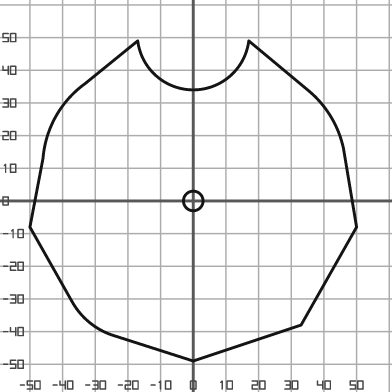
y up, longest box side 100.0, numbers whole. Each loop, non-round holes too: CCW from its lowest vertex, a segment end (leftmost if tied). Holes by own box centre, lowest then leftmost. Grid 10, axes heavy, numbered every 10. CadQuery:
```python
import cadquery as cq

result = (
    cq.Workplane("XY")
    .moveTo(0.0, -49.0)
    .lineTo(33.0, -38.0)
    .lineTo(50.0, -8.0)
    .lineTo(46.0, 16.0)
    .threePointArc((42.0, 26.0), (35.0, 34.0))
    .lineTo(17.0, 49.0)
    .threePointArc((0.0, 34.0), (-17.0, 49.0))
    .lineTo(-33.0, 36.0)
    .threePointArc((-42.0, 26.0), (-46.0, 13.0))
    .lineTo(-50.0, -8.0)
    .lineTo(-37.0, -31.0)
    .threePointArc((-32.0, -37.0), (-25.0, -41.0))
    .close()
    .moveTo(0.0, 0.0)
    .circle(3.0)
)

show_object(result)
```